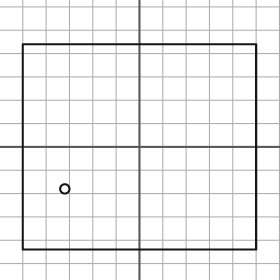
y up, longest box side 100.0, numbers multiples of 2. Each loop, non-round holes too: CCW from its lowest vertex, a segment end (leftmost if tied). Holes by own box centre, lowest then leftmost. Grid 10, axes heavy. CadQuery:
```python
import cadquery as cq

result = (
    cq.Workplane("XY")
    .moveTo(-50.0, -44.0)
    .lineTo(50.0, -44.0)
    .lineTo(50.0, 44.0)
    .lineTo(-50.0, 44.0)
    .close()
    .moveTo(-32.0, -18.0)
    .circle(2.0)
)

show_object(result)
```